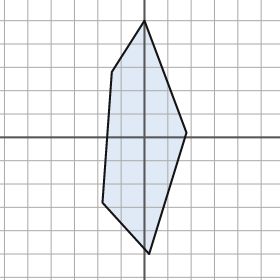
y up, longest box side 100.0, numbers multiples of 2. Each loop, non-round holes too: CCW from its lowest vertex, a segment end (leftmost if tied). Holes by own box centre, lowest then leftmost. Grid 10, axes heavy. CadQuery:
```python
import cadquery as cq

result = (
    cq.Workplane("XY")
    .moveTo(2.0, -50.0)
    .lineTo(18.0, 2.0)
    .lineTo(0.0, 50.0)
    .lineTo(-14.0, 28.0)
    .lineTo(-18.0, -28.0)
    .close()
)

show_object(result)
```